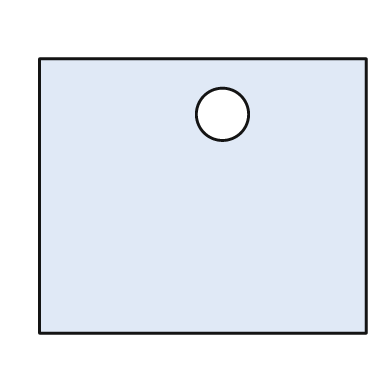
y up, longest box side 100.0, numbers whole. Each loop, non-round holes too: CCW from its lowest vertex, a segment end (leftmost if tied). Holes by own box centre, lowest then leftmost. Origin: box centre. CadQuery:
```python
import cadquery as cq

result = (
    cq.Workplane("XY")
    .moveTo(-50.0, -42.0)
    .lineTo(50.0, -42.0)
    .lineTo(50.0, 42.0)
    .lineTo(-50.0, 42.0)
    .close()
    .moveTo(6.0, 25.0)
    .circle(8.0)
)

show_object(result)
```